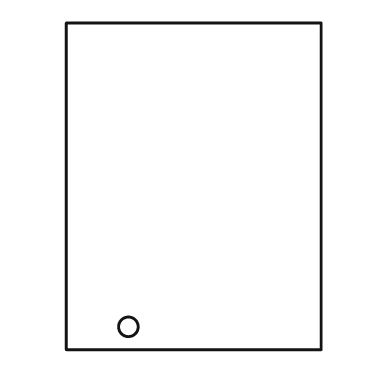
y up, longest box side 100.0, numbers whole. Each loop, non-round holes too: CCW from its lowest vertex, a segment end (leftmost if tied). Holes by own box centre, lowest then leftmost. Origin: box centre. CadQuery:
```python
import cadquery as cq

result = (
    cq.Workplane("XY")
    .moveTo(-39.0, -50.0)
    .lineTo(39.0, -50.0)
    .lineTo(39.0, 50.0)
    .lineTo(-39.0, 50.0)
    .close()
    .moveTo(-20.0, -43.0)
    .circle(3.0)
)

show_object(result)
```